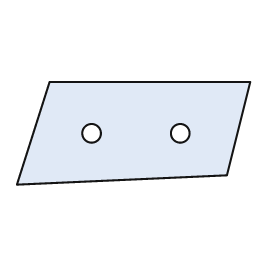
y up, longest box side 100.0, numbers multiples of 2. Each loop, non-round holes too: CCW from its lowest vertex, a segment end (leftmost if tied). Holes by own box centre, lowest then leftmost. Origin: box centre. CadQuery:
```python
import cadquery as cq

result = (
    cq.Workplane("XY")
    .moveTo(-50.0, -22.0)
    .lineTo(40.0, -18.0)
    .lineTo(50.0, 22.0)
    .lineTo(-36.0, 22.0)
    .close()
    .moveTo(-18.0, 0.0)
    .circle(4.0)
    .moveTo(20.0, 0.0)
    .circle(4.0)
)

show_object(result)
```